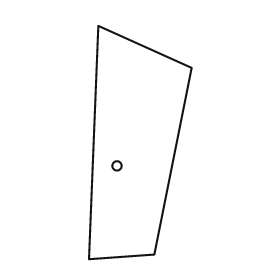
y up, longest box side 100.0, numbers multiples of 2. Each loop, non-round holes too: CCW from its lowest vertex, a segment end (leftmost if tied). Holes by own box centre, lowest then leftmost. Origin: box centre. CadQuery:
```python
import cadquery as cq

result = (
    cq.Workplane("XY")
    .moveTo(-22.0, -50.0)
    .lineTo(6.0, -48.0)
    .lineTo(22.0, 32.0)
    .lineTo(-18.0, 50.0)
    .close()
    .moveTo(-10.0, -10.0)
    .circle(2.0)
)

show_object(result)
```